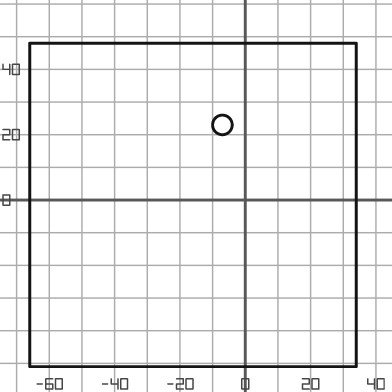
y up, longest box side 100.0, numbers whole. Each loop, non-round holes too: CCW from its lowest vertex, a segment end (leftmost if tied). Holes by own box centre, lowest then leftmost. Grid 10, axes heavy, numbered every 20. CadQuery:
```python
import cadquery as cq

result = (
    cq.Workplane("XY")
    .moveTo(-66.0, -51.0)
    .lineTo(34.0, -51.0)
    .lineTo(34.0, 48.0)
    .lineTo(-66.0, 48.0)
    .close()
    .moveTo(-7.0, 23.0)
    .circle(3.0)
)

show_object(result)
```